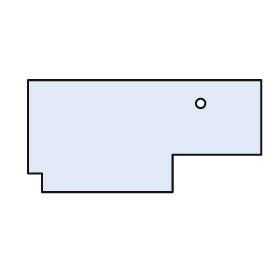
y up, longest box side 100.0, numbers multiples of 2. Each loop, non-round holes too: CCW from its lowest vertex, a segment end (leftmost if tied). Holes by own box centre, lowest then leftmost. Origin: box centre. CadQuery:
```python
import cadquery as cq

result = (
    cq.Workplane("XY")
    .moveTo(-44.0, -24.0)
    .lineTo(12.0, -24.0)
    .lineTo(12.0, -8.0)
    .lineTo(50.0, -8.0)
    .lineTo(50.0, 24.0)
    .lineTo(-50.0, 24.0)
    .lineTo(-50.0, -16.0)
    .lineTo(-44.0, -16.0)
    .close()
    .moveTo(24.0, 14.0)
    .circle(2.0)
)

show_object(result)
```